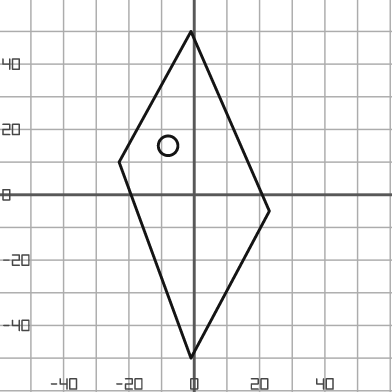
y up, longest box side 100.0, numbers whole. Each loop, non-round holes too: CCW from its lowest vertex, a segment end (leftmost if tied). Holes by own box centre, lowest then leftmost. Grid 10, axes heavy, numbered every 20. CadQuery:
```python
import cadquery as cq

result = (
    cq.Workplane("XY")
    .moveTo(-1.0, -50.0)
    .lineTo(23.0, -5.0)
    .lineTo(-1.0, 50.0)
    .lineTo(-23.0, 10.0)
    .close()
    .moveTo(-8.0, 15.0)
    .circle(3.0)
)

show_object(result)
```